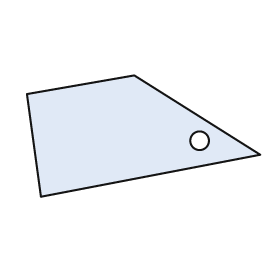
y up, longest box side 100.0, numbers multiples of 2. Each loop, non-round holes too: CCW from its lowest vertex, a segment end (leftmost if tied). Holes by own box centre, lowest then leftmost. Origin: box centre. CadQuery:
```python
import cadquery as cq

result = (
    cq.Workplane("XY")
    .moveTo(-44.0, -26.0)
    .lineTo(50.0, -8.0)
    .lineTo(-4.0, 26.0)
    .lineTo(-50.0, 18.0)
    .close()
    .moveTo(24.0, -2.0)
    .circle(4.0)
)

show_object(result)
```